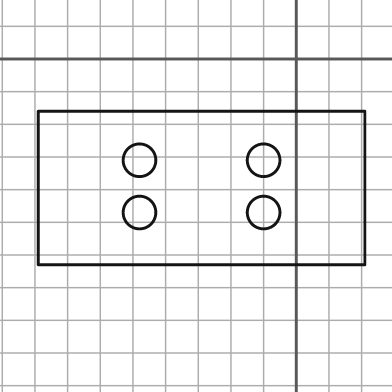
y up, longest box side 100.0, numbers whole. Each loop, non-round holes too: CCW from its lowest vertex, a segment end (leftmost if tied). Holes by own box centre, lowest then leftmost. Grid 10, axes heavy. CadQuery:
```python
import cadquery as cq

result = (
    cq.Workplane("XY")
    .moveTo(-79.0, -63.0)
    .lineTo(21.0, -63.0)
    .lineTo(21.0, -16.0)
    .lineTo(-79.0, -16.0)
    .close()
    .moveTo(-48.0, -47.0)
    .circle(5.0)
    .moveTo(-10.0, -47.0)
    .circle(5.0)
    .moveTo(-48.0, -31.0)
    .circle(5.0)
    .moveTo(-10.0, -31.0)
    .circle(5.0)
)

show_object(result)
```